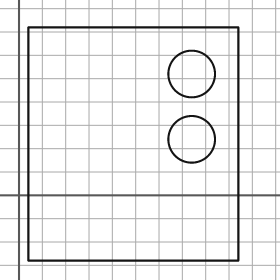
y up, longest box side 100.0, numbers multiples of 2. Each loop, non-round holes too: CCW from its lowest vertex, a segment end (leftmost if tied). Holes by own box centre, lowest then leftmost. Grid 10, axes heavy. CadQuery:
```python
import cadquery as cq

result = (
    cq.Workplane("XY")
    .moveTo(4.0, -28.0)
    .lineTo(94.0, -28.0)
    .lineTo(94.0, 72.0)
    .lineTo(4.0, 72.0)
    .close()
    .moveTo(74.0, 24.0)
    .circle(10.0)
    .moveTo(74.0, 52.0)
    .circle(10.0)
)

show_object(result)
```